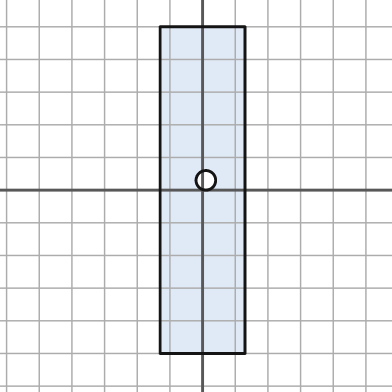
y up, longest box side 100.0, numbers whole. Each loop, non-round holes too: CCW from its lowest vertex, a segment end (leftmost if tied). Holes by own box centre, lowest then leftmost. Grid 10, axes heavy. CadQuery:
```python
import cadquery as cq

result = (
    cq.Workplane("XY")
    .moveTo(-13.0, -50.0)
    .lineTo(13.0, -50.0)
    .lineTo(13.0, 50.0)
    .lineTo(-13.0, 50.0)
    .close()
    .moveTo(1.0, 3.0)
    .circle(3.0)
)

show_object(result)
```